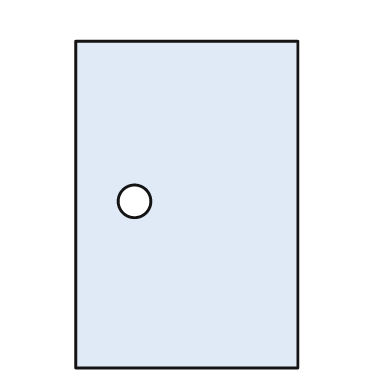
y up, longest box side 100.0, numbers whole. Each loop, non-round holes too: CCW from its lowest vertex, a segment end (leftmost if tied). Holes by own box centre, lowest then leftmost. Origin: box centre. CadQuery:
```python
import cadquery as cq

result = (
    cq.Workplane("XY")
    .moveTo(-34.0, -50.0)
    .lineTo(34.0, -50.0)
    .lineTo(34.0, 50.0)
    .lineTo(-34.0, 50.0)
    .close()
    .moveTo(-16.0, 1.0)
    .circle(5.0)
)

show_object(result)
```